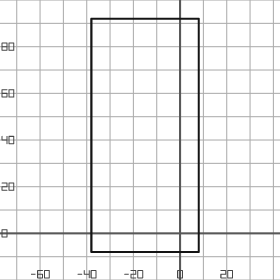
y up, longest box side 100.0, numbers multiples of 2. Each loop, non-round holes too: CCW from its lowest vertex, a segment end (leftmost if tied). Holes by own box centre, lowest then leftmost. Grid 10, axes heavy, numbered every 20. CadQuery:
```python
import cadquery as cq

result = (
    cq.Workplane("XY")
    .moveTo(-38.0, -8.0)
    .lineTo(8.0, -8.0)
    .lineTo(8.0, 92.0)
    .lineTo(-38.0, 92.0)
    .close()
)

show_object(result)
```